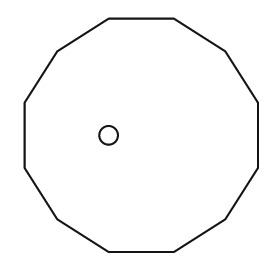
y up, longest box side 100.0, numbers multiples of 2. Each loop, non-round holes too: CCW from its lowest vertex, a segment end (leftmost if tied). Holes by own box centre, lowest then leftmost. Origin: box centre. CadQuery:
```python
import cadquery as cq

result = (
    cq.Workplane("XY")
    .moveTo(-14.0, -50.0)
    .lineTo(14.0, -50.0)
    .lineTo(36.0, -36.0)
    .lineTo(50.0, -14.0)
    .lineTo(50.0, 14.0)
    .lineTo(36.0, 36.0)
    .lineTo(14.0, 50.0)
    .lineTo(-14.0, 50.0)
    .lineTo(-36.0, 36.0)
    .lineTo(-50.0, 14.0)
    .lineTo(-50.0, -14.0)
    .lineTo(-36.0, -36.0)
    .close()
    .moveTo(-14.0, 0.0)
    .circle(4.0)
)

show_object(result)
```